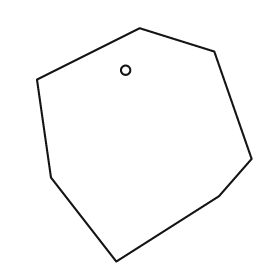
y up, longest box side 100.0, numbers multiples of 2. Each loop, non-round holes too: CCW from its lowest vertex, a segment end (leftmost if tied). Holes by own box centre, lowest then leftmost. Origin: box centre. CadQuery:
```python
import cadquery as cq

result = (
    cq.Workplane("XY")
    .moveTo(-12.0, -50.0)
    .lineTo(32.0, -22.0)
    .lineTo(46.0, -6.0)
    .lineTo(30.0, 40.0)
    .lineTo(-2.0, 50.0)
    .lineTo(-46.0, 28.0)
    .lineTo(-40.0, -14.0)
    .close()
    .moveTo(-8.0, 32.0)
    .circle(2.0)
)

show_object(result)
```